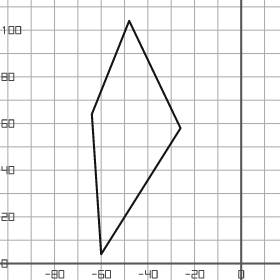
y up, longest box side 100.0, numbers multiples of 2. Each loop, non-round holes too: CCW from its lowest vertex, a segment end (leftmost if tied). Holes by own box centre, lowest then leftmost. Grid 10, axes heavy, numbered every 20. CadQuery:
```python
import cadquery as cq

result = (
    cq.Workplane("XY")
    .moveTo(-60.0, 4.0)
    .lineTo(-26.0, 58.0)
    .lineTo(-48.0, 104.0)
    .lineTo(-64.0, 64.0)
    .close()
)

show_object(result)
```